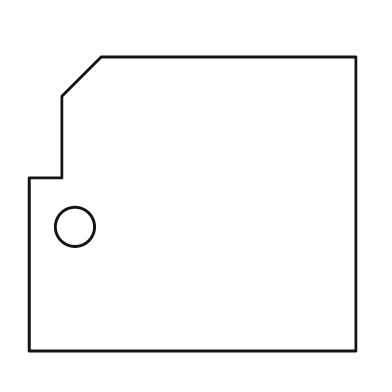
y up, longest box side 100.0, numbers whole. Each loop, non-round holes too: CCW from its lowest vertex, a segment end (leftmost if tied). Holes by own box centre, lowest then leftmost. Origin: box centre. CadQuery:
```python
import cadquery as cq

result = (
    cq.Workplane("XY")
    .moveTo(-50.0, -45.0)
    .lineTo(50.0, -45.0)
    .lineTo(50.0, 45.0)
    .lineTo(-28.0, 45.0)
    .lineTo(-40.0, 33.0)
    .lineTo(-40.0, 8.0)
    .lineTo(-50.0, 8.0)
    .close()
    .moveTo(-36.0, -7.0)
    .circle(6.0)
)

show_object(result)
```